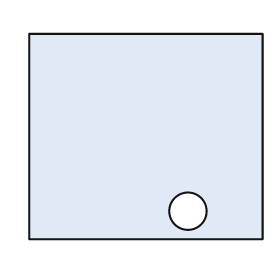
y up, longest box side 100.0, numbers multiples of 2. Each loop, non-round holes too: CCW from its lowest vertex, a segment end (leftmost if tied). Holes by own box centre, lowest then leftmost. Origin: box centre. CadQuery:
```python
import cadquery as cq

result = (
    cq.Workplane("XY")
    .moveTo(-50.0, -44.0)
    .lineTo(50.0, -44.0)
    .lineTo(50.0, 44.0)
    .lineTo(-50.0, 44.0)
    .close()
    .moveTo(18.0, -32.0)
    .circle(8.0)
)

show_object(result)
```